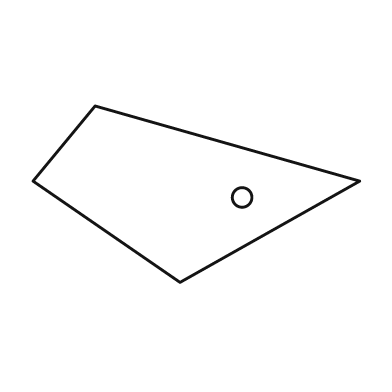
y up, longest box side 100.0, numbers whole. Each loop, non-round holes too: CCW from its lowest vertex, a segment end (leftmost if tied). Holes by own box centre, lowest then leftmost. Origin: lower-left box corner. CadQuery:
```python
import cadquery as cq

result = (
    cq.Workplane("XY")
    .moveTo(45.0, 0.0)
    .lineTo(100.0, 31.0)
    .lineTo(19.0, 54.0)
    .lineTo(0.0, 31.0)
    .close()
    .moveTo(64.0, 26.0)
    .circle(3.0)
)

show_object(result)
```